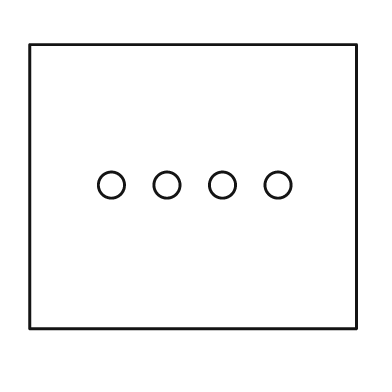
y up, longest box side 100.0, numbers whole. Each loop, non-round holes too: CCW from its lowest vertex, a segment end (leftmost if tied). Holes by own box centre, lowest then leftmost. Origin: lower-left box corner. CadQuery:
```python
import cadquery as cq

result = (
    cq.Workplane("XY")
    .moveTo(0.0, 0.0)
    .lineTo(100.0, 0.0)
    .lineTo(100.0, 87.0)
    .lineTo(0.0, 87.0)
    .close()
    .moveTo(25.0, 44.0)
    .circle(4.0)
    .moveTo(42.0, 44.0)
    .circle(4.0)
    .moveTo(59.0, 44.0)
    .circle(4.0)
    .moveTo(76.0, 44.0)
    .circle(4.0)
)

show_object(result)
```